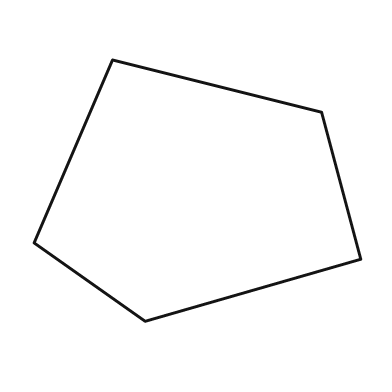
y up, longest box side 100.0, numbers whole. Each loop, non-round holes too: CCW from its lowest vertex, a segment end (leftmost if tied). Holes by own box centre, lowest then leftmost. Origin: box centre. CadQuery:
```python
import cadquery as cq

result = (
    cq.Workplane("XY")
    .moveTo(-16.0, -40.0)
    .lineTo(50.0, -21.0)
    .lineTo(38.0, 24.0)
    .lineTo(-26.0, 40.0)
    .lineTo(-50.0, -16.0)
    .close()
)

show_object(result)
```